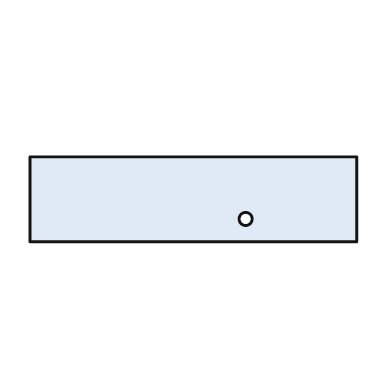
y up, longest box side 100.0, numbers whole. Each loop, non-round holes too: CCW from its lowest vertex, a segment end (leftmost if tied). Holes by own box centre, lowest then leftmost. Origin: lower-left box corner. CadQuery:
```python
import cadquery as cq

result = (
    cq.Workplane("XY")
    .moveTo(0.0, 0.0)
    .lineTo(100.0, 0.0)
    .lineTo(100.0, 26.0)
    .lineTo(0.0, 26.0)
    .close()
    .moveTo(66.0, 7.0)
    .circle(2.0)
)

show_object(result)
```